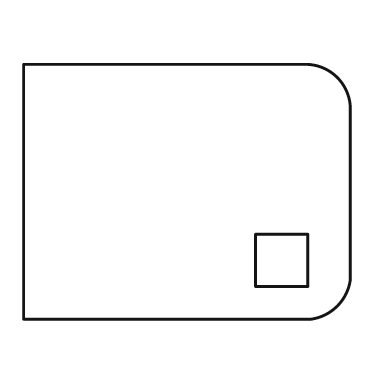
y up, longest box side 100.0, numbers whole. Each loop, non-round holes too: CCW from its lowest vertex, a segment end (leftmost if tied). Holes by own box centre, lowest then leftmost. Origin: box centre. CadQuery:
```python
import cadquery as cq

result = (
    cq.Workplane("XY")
    .moveTo(-50.0, -39.0)
    .lineTo(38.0, -39.0)
    .threePointArc((46.0, -35.0), (50.0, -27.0))
    .lineTo(50.0, 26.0)
    .threePointArc((46.0, 35.0), (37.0, 39.0))
    .lineTo(-50.0, 39.0)
    .close()
    .moveTo(21.0, -29.0)
    .lineTo(37.0, -29.0)
    .lineTo(37.0, -13.0)
    .lineTo(21.0, -13.0)
    .close()
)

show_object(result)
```